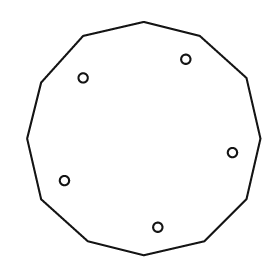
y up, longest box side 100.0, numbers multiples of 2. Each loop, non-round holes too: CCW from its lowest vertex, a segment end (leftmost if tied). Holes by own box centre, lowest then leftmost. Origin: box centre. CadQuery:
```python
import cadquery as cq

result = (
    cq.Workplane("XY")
    .moveTo(0.0, -50.0)
    .lineTo(26.0, -44.0)
    .lineTo(44.0, -26.0)
    .lineTo(50.0, 0.0)
    .lineTo(44.0, 26.0)
    .lineTo(24.0, 44.0)
    .lineTo(0.0, 50.0)
    .lineTo(-26.0, 44.0)
    .lineTo(-44.0, 24.0)
    .lineTo(-50.0, 0.0)
    .lineTo(-44.0, -26.0)
    .lineTo(-24.0, -44.0)
    .close()
    .moveTo(6.0, -38.0)
    .circle(2.0)
    .moveTo(-34.0, -18.0)
    .circle(2.0)
    .moveTo(38.0, -6.0)
    .circle(2.0)
    .moveTo(-26.0, 26.0)
    .circle(2.0)
    .moveTo(18.0, 34.0)
    .circle(2.0)
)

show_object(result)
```